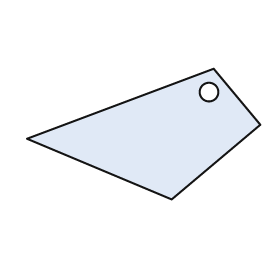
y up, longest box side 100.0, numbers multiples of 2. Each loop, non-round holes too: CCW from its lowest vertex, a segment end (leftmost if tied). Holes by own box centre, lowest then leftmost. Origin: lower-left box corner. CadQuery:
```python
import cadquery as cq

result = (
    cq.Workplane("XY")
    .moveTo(62.0, 0.0)
    .lineTo(100.0, 32.0)
    .lineTo(80.0, 56.0)
    .lineTo(0.0, 26.0)
    .close()
    .moveTo(78.0, 46.0)
    .circle(4.0)
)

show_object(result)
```